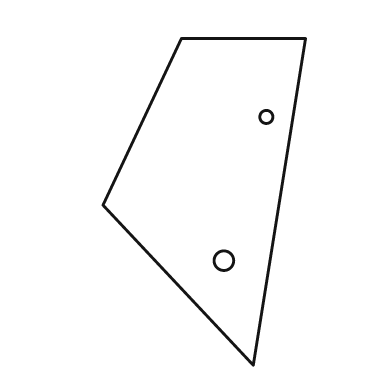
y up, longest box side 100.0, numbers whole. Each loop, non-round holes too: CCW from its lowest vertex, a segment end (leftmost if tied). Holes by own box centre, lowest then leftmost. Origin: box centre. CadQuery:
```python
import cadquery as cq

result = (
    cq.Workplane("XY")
    .moveTo(15.0, -50.0)
    .lineTo(31.0, 50.0)
    .lineTo(-7.0, 50.0)
    .lineTo(-31.0, -1.0)
    .close()
    .moveTo(6.0, -18.0)
    .circle(3.0)
    .moveTo(19.0, 26.0)
    .circle(2.0)
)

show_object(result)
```